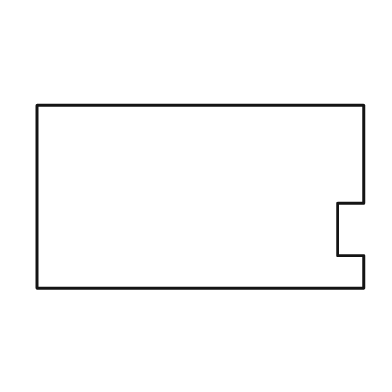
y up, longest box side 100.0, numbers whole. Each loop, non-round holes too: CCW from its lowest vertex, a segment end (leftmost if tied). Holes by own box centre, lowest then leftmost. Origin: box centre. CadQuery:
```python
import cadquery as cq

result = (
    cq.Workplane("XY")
    .moveTo(-50.0, -28.0)
    .lineTo(50.0, -28.0)
    .lineTo(50.0, -18.0)
    .lineTo(42.0, -18.0)
    .lineTo(42.0, -2.0)
    .lineTo(50.0, -2.0)
    .lineTo(50.0, 28.0)
    .lineTo(-50.0, 28.0)
    .close()
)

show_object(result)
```